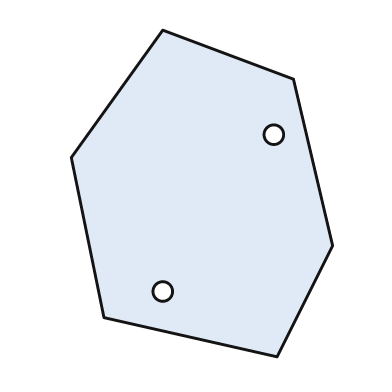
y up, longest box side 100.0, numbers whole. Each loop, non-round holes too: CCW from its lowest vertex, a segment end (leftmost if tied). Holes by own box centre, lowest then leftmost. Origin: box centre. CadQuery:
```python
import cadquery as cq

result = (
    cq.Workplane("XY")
    .moveTo(23.0, -50.0)
    .lineTo(40.0, -16.0)
    .lineTo(28.0, 35.0)
    .lineTo(-12.0, 50.0)
    .lineTo(-40.0, 11.0)
    .lineTo(-30.0, -38.0)
    .close()
    .moveTo(-12.0, -30.0)
    .circle(3.0)
    .moveTo(22.0, 18.0)
    .circle(3.0)
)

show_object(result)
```